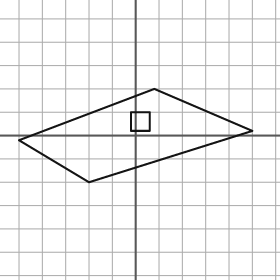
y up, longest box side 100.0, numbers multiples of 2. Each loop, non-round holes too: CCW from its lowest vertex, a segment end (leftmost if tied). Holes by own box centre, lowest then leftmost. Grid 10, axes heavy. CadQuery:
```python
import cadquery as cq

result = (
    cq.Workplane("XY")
    .moveTo(-20.0, -20.0)
    .lineTo(50.0, 2.0)
    .lineTo(8.0, 20.0)
    .lineTo(-50.0, -2.0)
    .close()
    .moveTo(-2.0, 2.0)
    .lineTo(6.0, 2.0)
    .lineTo(6.0, 10.0)
    .lineTo(-2.0, 10.0)
    .close()
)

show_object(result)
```